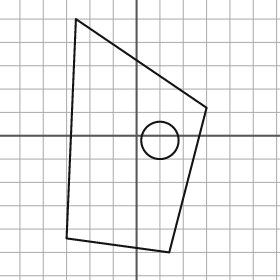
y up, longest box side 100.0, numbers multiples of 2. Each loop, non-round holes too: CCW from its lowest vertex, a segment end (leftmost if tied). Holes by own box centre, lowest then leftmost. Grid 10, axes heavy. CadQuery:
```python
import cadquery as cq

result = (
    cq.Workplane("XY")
    .moveTo(14.0, -50.0)
    .lineTo(30.0, 12.0)
    .lineTo(-26.0, 50.0)
    .lineTo(-30.0, -44.0)
    .close()
    .moveTo(10.0, -2.0)
    .circle(8.0)
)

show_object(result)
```